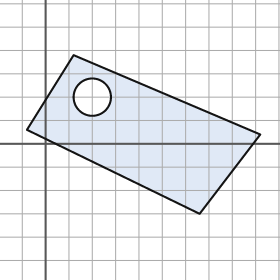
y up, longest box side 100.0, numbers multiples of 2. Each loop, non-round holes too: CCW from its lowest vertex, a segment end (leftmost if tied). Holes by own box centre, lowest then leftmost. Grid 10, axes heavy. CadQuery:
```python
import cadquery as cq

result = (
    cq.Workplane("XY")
    .moveTo(66.0, -30.0)
    .lineTo(92.0, 4.0)
    .lineTo(12.0, 38.0)
    .lineTo(-8.0, 6.0)
    .close()
    .moveTo(20.0, 20.0)
    .circle(8.0)
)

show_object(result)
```